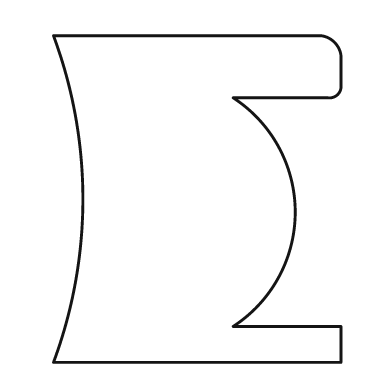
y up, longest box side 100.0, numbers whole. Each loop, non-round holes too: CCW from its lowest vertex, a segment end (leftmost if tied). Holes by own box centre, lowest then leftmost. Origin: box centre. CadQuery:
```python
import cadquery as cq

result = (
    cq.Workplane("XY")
    .moveTo(-44.0, -50.0)
    .lineTo(44.0, -50.0)
    .lineTo(44.0, -39.0)
    .lineTo(11.0, -39.0)
    .threePointArc((30.0, -4.0), (11.0, 31.0))
    .lineTo(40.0, 31.0)
    .threePointArc((43.0, 32.0), (44.0, 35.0))
    .lineTo(44.0, 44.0)
    .threePointArc((42.0, 48.0), (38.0, 50.0))
    .lineTo(-44.0, 50.0)
    .threePointArc((-35.0, 0.0), (-44.0, -50.0))
    .close()
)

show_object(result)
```